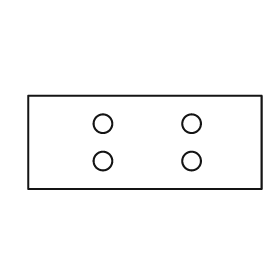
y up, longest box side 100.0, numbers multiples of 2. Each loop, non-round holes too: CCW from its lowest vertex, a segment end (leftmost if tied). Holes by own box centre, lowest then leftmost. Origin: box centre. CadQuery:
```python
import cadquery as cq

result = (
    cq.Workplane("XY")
    .moveTo(-50.0, -20.0)
    .lineTo(50.0, -20.0)
    .lineTo(50.0, 20.0)
    .lineTo(-50.0, 20.0)
    .close()
    .moveTo(-18.0, -8.0)
    .circle(4.0)
    .moveTo(20.0, -8.0)
    .circle(4.0)
    .moveTo(-18.0, 8.0)
    .circle(4.0)
    .moveTo(20.0, 8.0)
    .circle(4.0)
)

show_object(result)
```